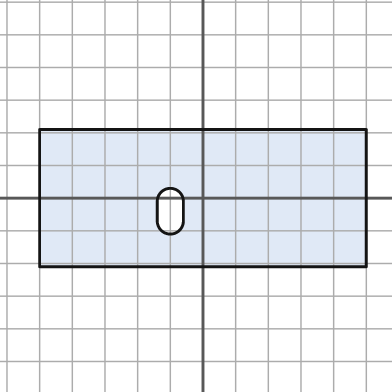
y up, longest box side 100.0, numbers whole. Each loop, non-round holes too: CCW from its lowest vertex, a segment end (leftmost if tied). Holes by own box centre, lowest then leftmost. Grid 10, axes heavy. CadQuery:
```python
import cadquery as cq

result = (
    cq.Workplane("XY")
    .moveTo(-50.0, -21.0)
    .lineTo(50.0, -21.0)
    .lineTo(50.0, 21.0)
    .lineTo(-50.0, 21.0)
    .close()
    .moveTo(-14.0, -7.0)
    .threePointArc((-10.0, -11.0), (-6.0, -7.0))
    .lineTo(-6.0, -1.0)
    .threePointArc((-10.0, 3.0), (-14.0, -1.0))
    .close()
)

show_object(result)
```